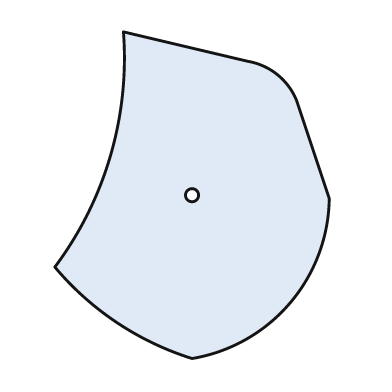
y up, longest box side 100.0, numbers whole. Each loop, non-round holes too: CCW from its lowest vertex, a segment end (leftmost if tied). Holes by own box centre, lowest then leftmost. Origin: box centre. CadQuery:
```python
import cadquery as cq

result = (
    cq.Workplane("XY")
    .moveTo(0.0, -50.0)
    .threePointArc((30.0, -33.0), (42.0, -1.0))
    .lineTo(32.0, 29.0)
    .threePointArc((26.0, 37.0), (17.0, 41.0))
    .lineTo(-21.0, 50.0)
    .threePointArc((-25.0, 12.0), (-42.0, -22.0))
    .threePointArc((-23.0, -39.0), (0.0, -50.0))
    .close()
    .moveTo(0.0, 0.0)
    .circle(2.0)
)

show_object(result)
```